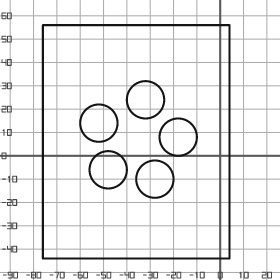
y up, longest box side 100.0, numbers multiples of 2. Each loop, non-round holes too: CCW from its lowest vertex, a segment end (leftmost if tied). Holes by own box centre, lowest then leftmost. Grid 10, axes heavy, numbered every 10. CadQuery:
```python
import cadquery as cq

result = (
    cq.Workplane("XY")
    .moveTo(-76.0, -44.0)
    .lineTo(4.0, -44.0)
    .lineTo(4.0, 56.0)
    .lineTo(-76.0, 56.0)
    .close()
    .moveTo(-28.0, -10.0)
    .circle(8.0)
    .moveTo(-48.0, -6.0)
    .circle(8.0)
    .moveTo(-18.0, 8.0)
    .circle(8.0)
    .moveTo(-52.0, 14.0)
    .circle(8.0)
    .moveTo(-32.0, 24.0)
    .circle(8.0)
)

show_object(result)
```